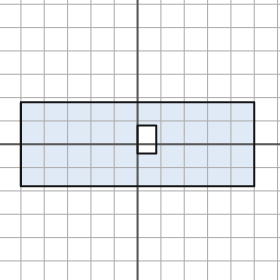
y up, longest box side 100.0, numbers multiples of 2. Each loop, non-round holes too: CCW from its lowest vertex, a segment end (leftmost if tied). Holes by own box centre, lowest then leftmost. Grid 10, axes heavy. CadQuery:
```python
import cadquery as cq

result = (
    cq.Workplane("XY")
    .moveTo(-50.0, -18.0)
    .lineTo(50.0, -18.0)
    .lineTo(50.0, 18.0)
    .lineTo(-50.0, 18.0)
    .close()
    .moveTo(0.0, -4.0)
    .lineTo(8.0, -4.0)
    .lineTo(8.0, 8.0)
    .lineTo(0.0, 8.0)
    .close()
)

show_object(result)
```